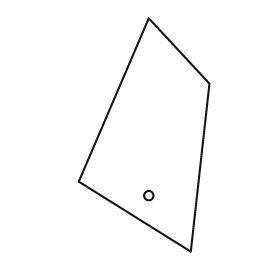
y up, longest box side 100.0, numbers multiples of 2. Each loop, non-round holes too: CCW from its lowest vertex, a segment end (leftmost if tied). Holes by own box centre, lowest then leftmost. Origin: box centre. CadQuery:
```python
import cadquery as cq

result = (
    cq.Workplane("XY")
    .moveTo(20.0, -50.0)
    .lineTo(28.0, 22.0)
    .lineTo(2.0, 50.0)
    .lineTo(-28.0, -20.0)
    .close()
    .moveTo(2.0, -26.0)
    .circle(2.0)
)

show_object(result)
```